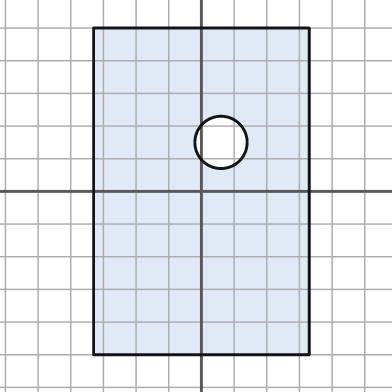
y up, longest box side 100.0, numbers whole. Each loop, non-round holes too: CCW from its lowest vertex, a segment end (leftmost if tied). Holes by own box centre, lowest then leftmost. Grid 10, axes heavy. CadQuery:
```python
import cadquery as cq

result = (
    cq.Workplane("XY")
    .moveTo(-33.0, -50.0)
    .lineTo(33.0, -50.0)
    .lineTo(33.0, 50.0)
    .lineTo(-33.0, 50.0)
    .close()
    .moveTo(6.0, 15.0)
    .circle(8.0)
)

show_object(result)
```